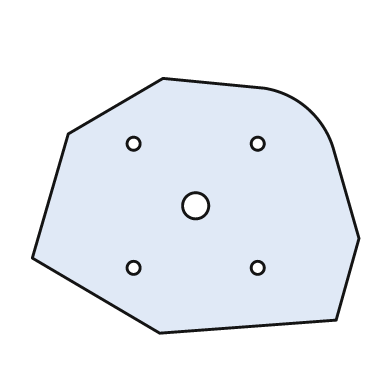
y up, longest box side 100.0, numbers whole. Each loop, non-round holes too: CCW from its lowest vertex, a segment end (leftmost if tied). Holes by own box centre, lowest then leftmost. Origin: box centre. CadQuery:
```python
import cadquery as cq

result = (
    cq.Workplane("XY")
    .moveTo(-11.0, -39.0)
    .lineTo(43.0, -35.0)
    .lineTo(50.0, -10.0)
    .lineTo(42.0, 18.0)
    .threePointArc((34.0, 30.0), (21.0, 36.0))
    .lineTo(-10.0, 39.0)
    .lineTo(-39.0, 22.0)
    .lineTo(-50.0, -16.0)
    .close()
    .moveTo(-19.0, -19.0)
    .circle(2.0)
    .moveTo(19.0, -19.0)
    .circle(2.0)
    .moveTo(0.0, 0.0)
    .circle(4.0)
    .moveTo(-19.0, 19.0)
    .circle(2.0)
    .moveTo(19.0, 19.0)
    .circle(2.0)
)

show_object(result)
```